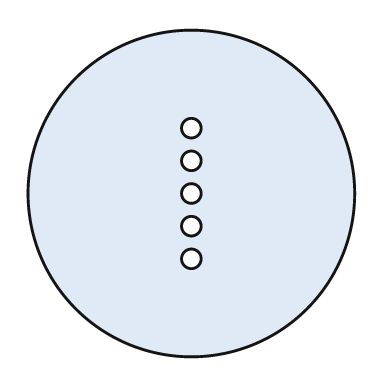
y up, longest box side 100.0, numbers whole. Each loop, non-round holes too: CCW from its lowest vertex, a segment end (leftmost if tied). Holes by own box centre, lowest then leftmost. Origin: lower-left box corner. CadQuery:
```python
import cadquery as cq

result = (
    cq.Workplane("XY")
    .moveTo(50.0, 50.0)
    .circle(50.0)
    .moveTo(50.0, 30.0)
    .circle(3.0)
    .moveTo(50.0, 40.0)
    .circle(3.0)
    .moveTo(50.0, 50.0)
    .circle(3.0)
    .moveTo(50.0, 60.0)
    .circle(3.0)
    .moveTo(50.0, 70.0)
    .circle(3.0)
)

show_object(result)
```